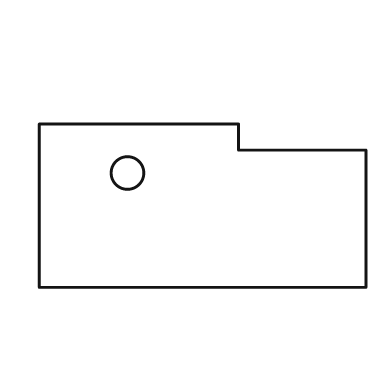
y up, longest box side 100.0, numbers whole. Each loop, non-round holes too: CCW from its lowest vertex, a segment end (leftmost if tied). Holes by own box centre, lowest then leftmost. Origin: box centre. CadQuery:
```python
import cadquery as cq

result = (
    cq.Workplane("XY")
    .moveTo(-50.0, -25.0)
    .lineTo(50.0, -25.0)
    .lineTo(50.0, 17.0)
    .lineTo(11.0, 17.0)
    .lineTo(11.0, 25.0)
    .lineTo(-50.0, 25.0)
    .close()
    .moveTo(-23.0, 10.0)
    .circle(5.0)
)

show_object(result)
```